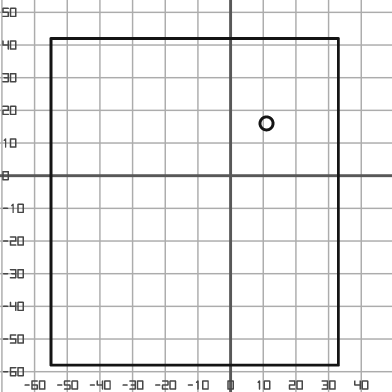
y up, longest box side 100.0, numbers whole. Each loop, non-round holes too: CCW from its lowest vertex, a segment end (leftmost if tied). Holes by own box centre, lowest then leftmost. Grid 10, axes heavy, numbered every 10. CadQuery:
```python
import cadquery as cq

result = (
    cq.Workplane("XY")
    .moveTo(-55.0, -58.0)
    .lineTo(33.0, -58.0)
    .lineTo(33.0, 42.0)
    .lineTo(-55.0, 42.0)
    .close()
    .moveTo(11.0, 16.0)
    .circle(2.0)
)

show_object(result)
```